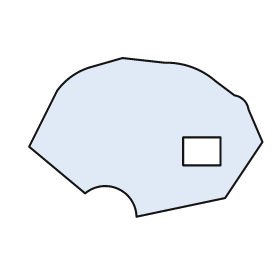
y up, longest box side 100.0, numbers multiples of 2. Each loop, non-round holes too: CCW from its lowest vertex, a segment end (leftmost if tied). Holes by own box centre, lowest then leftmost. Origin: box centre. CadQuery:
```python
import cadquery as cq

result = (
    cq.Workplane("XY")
    .moveTo(-4.0, -34.0)
    .lineTo(34.0, -26.0)
    .lineTo(50.0, -2.0)
    .lineTo(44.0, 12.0)
    .threePointArc((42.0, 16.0), (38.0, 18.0))
    .lineTo(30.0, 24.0)
    .threePointArc((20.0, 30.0), (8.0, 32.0))
    .lineTo(-10.0, 34.0)
    .lineTo(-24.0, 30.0)
    .threePointArc((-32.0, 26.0), (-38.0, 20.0))
    .lineTo(-50.0, -4.0)
    .lineTo(-26.0, -24.0)
    .threePointArc((-12.0, -22.0), (-4.0, -34.0))
    .close()
    .moveTo(16.0, -12.0)
    .lineTo(32.0, -12.0)
    .lineTo(32.0, 0.0)
    .lineTo(16.0, 0.0)
    .close()
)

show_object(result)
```